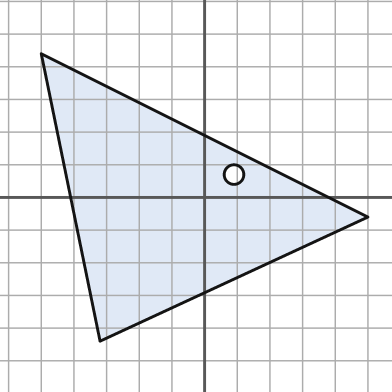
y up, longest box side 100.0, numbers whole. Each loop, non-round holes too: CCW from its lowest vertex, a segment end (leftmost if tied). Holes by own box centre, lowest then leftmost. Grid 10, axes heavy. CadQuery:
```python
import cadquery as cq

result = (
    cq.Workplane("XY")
    .moveTo(-32.0, -44.0)
    .lineTo(50.0, -6.0)
    .lineTo(-50.0, 44.0)
    .close()
    .moveTo(9.0, 7.0)
    .circle(3.0)
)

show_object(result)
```